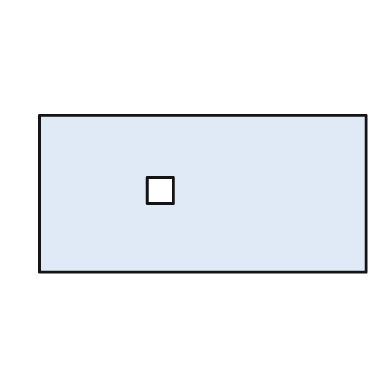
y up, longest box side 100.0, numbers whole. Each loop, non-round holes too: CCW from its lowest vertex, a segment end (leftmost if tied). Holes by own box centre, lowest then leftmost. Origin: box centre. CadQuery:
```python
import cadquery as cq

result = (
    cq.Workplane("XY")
    .moveTo(-50.0, -24.0)
    .lineTo(50.0, -24.0)
    .lineTo(50.0, 24.0)
    .lineTo(-50.0, 24.0)
    .close()
    .moveTo(-17.0, -3.0)
    .lineTo(-9.0, -3.0)
    .lineTo(-9.0, 5.0)
    .lineTo(-17.0, 5.0)
    .close()
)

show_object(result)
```